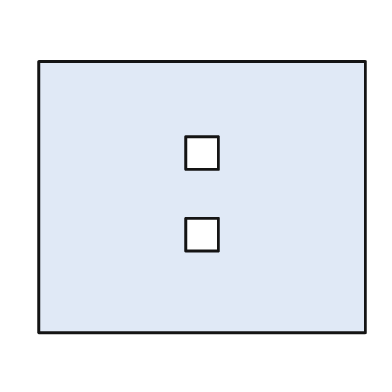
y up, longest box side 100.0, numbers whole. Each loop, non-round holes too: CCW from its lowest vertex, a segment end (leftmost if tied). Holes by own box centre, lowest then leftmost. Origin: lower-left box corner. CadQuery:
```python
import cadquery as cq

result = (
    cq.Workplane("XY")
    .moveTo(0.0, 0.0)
    .lineTo(100.0, 0.0)
    .lineTo(100.0, 83.0)
    .lineTo(0.0, 83.0)
    .close()
    .moveTo(45.0, 25.0)
    .lineTo(55.0, 25.0)
    .lineTo(55.0, 35.0)
    .lineTo(45.0, 35.0)
    .close()
    .moveTo(45.0, 50.0)
    .lineTo(55.0, 50.0)
    .lineTo(55.0, 60.0)
    .lineTo(45.0, 60.0)
    .close()
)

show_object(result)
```